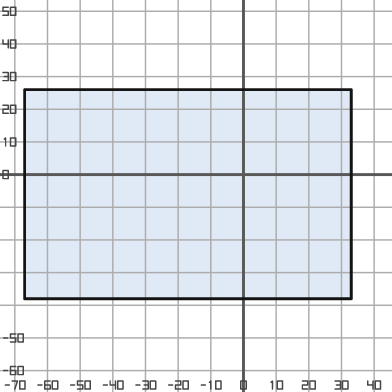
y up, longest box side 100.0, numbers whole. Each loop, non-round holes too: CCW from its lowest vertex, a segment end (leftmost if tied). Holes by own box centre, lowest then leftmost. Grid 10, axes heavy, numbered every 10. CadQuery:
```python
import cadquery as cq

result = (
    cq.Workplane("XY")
    .moveTo(-67.0, -38.0)
    .lineTo(33.0, -38.0)
    .lineTo(33.0, 26.0)
    .lineTo(-67.0, 26.0)
    .close()
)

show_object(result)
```